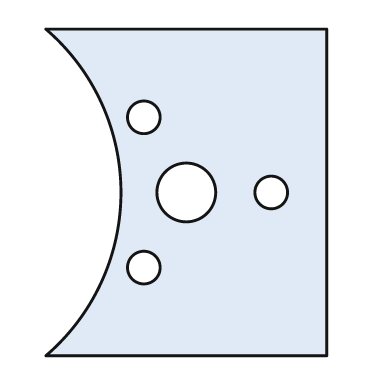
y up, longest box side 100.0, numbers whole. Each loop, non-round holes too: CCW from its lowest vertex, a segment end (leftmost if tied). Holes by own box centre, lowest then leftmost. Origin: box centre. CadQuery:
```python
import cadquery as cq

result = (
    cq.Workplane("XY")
    .moveTo(-43.0, -50.0)
    .lineTo(43.0, -50.0)
    .lineTo(43.0, 50.0)
    .lineTo(-43.0, 50.0)
    .threePointArc((-20.0, 0.0), (-43.0, -50.0))
    .close()
    .moveTo(-13.0, -23.0)
    .circle(5.0)
    .moveTo(0.0, 0.0)
    .circle(9.0)
    .moveTo(26.0, 0.0)
    .circle(5.0)
    .moveTo(-13.0, 23.0)
    .circle(5.0)
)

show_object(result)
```